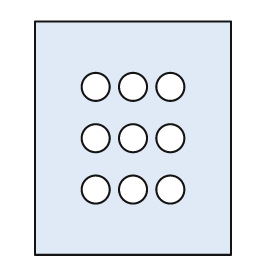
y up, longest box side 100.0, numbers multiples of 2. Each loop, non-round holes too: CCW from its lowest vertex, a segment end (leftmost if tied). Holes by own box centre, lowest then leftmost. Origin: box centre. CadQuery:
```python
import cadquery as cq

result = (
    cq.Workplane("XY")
    .moveTo(-42.0, -50.0)
    .lineTo(42.0, -50.0)
    .lineTo(42.0, 50.0)
    .lineTo(-42.0, 50.0)
    .close()
    .moveTo(-16.0, -22.0)
    .circle(6.0)
    .moveTo(0.0, -22.0)
    .circle(6.0)
    .moveTo(16.0, -22.0)
    .circle(6.0)
    .moveTo(-16.0, 0.0)
    .circle(6.0)
    .moveTo(0.0, 0.0)
    .circle(6.0)
    .moveTo(16.0, 0.0)
    .circle(6.0)
    .moveTo(-16.0, 22.0)
    .circle(6.0)
    .moveTo(0.0, 22.0)
    .circle(6.0)
    .moveTo(16.0, 22.0)
    .circle(6.0)
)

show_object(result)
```